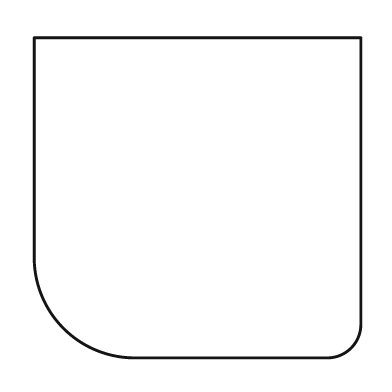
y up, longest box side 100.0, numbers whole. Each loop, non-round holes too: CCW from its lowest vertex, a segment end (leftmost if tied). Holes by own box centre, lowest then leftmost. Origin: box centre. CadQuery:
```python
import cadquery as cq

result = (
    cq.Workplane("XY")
    .moveTo(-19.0, -49.0)
    .lineTo(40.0, -49.0)
    .threePointArc((47.0, -46.0), (50.0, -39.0))
    .lineTo(50.0, 49.0)
    .lineTo(-50.0, 49.0)
    .lineTo(-50.0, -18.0)
    .threePointArc((-41.0, -40.0), (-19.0, -49.0))
    .close()
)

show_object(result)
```